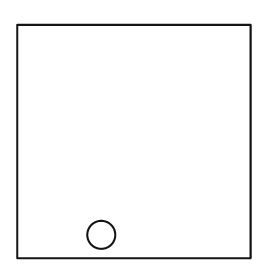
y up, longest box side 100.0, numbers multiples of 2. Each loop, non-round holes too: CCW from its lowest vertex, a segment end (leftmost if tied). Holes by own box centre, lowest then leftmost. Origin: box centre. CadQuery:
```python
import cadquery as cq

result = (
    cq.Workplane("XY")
    .moveTo(-50.0, -50.0)
    .lineTo(50.0, -50.0)
    .lineTo(50.0, 50.0)
    .lineTo(-50.0, 50.0)
    .close()
    .moveTo(-14.0, -40.0)
    .circle(6.0)
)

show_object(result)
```